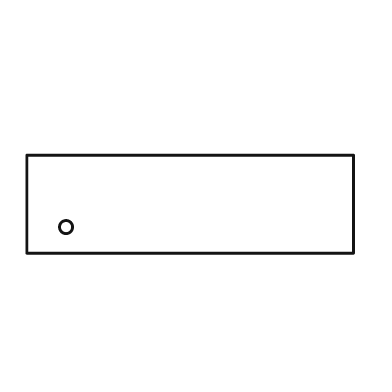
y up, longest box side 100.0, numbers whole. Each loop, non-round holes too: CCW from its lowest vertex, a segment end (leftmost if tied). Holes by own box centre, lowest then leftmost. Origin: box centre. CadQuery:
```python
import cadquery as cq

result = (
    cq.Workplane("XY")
    .moveTo(-50.0, -15.0)
    .lineTo(50.0, -15.0)
    .lineTo(50.0, 15.0)
    .lineTo(-50.0, 15.0)
    .close()
    .moveTo(-38.0, -7.0)
    .circle(2.0)
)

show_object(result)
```